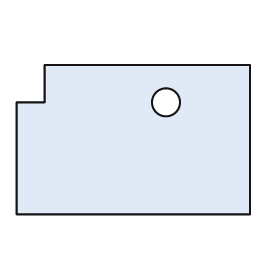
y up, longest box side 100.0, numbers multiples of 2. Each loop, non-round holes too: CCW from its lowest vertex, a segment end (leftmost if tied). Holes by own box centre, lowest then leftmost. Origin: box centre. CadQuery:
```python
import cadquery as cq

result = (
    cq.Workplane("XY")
    .moveTo(-50.0, -32.0)
    .lineTo(50.0, -32.0)
    .lineTo(50.0, 32.0)
    .lineTo(-38.0, 32.0)
    .lineTo(-38.0, 16.0)
    .lineTo(-50.0, 16.0)
    .close()
    .moveTo(14.0, 16.0)
    .circle(6.0)
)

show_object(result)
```